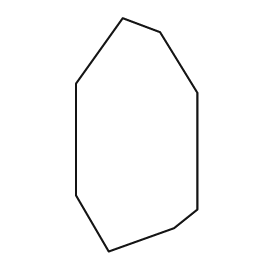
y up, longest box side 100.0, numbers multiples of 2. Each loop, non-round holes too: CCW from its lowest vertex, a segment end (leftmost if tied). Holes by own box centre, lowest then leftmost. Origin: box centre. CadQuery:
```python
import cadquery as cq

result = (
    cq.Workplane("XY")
    .moveTo(-12.0, -50.0)
    .lineTo(16.0, -40.0)
    .lineTo(26.0, -32.0)
    .lineTo(26.0, 18.0)
    .lineTo(10.0, 44.0)
    .lineTo(-6.0, 50.0)
    .lineTo(-26.0, 22.0)
    .lineTo(-26.0, -26.0)
    .close()
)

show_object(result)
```